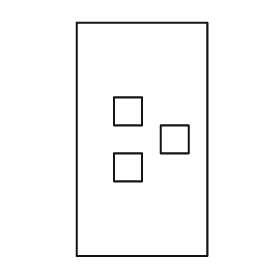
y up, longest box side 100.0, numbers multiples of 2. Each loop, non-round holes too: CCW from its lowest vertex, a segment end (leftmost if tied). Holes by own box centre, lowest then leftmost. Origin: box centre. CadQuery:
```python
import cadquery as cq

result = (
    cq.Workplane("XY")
    .moveTo(-28.0, -50.0)
    .lineTo(28.0, -50.0)
    .lineTo(28.0, 50.0)
    .lineTo(-28.0, 50.0)
    .close()
    .moveTo(-12.0, -18.0)
    .lineTo(0.0, -18.0)
    .lineTo(0.0, -6.0)
    .lineTo(-12.0, -6.0)
    .close()
    .moveTo(8.0, -6.0)
    .lineTo(20.0, -6.0)
    .lineTo(20.0, 6.0)
    .lineTo(8.0, 6.0)
    .close()
    .moveTo(-12.0, 6.0)
    .lineTo(0.0, 6.0)
    .lineTo(0.0, 18.0)
    .lineTo(-12.0, 18.0)
    .close()
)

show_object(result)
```